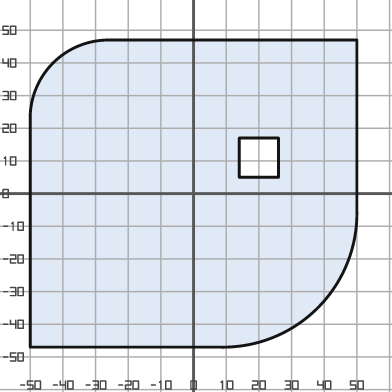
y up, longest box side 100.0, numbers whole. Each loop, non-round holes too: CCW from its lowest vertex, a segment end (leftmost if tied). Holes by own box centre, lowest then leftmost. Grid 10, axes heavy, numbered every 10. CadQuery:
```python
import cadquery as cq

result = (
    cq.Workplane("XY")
    .moveTo(-50.0, -47.0)
    .lineTo(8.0, -47.0)
    .threePointArc((38.0, -35.0), (50.0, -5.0))
    .lineTo(50.0, 47.0)
    .lineTo(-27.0, 47.0)
    .threePointArc((-43.0, 40.0), (-50.0, 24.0))
    .close()
    .moveTo(14.0, 5.0)
    .lineTo(26.0, 5.0)
    .lineTo(26.0, 17.0)
    .lineTo(14.0, 17.0)
    .close()
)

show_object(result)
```